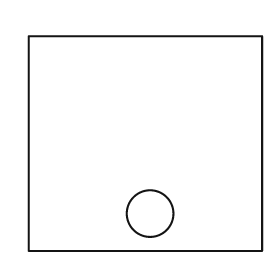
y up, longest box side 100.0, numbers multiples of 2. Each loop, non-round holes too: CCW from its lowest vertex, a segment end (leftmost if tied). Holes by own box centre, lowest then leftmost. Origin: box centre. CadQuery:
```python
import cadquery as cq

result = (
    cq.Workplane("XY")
    .moveTo(-50.0, -46.0)
    .lineTo(50.0, -46.0)
    .lineTo(50.0, 46.0)
    .lineTo(-50.0, 46.0)
    .close()
    .moveTo(2.0, -30.0)
    .circle(10.0)
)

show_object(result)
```